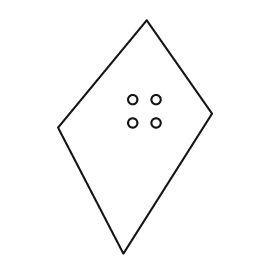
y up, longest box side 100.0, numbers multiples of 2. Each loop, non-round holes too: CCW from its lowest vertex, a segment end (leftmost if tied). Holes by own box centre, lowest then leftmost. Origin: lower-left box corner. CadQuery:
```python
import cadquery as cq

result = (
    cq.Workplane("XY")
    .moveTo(28.0, 0.0)
    .lineTo(66.0, 60.0)
    .lineTo(38.0, 100.0)
    .lineTo(0.0, 54.0)
    .close()
    .moveTo(32.0, 56.0)
    .circle(2.0)
    .moveTo(42.0, 56.0)
    .circle(2.0)
    .moveTo(32.0, 66.0)
    .circle(2.0)
    .moveTo(42.0, 66.0)
    .circle(2.0)
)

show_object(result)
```